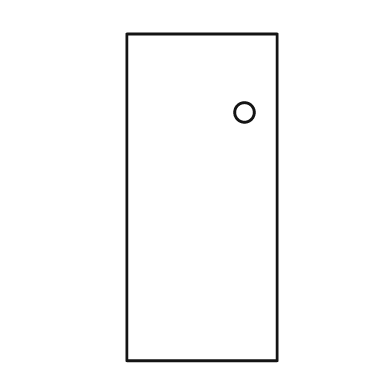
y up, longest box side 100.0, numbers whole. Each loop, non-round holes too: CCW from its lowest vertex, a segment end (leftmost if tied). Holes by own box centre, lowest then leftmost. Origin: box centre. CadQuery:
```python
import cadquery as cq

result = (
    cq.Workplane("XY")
    .moveTo(-23.0, -50.0)
    .lineTo(23.0, -50.0)
    .lineTo(23.0, 50.0)
    .lineTo(-23.0, 50.0)
    .close()
    .moveTo(13.0, 26.0)
    .circle(3.0)
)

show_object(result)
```